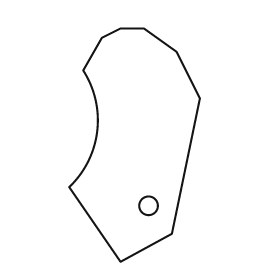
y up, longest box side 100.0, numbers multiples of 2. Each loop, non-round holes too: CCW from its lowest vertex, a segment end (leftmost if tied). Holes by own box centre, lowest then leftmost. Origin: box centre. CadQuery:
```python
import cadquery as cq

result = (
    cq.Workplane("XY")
    .moveTo(-6.0, -50.0)
    .lineTo(16.0, -38.0)
    .lineTo(28.0, 20.0)
    .lineTo(18.0, 40.0)
    .lineTo(4.0, 50.0)
    .lineTo(-6.0, 50.0)
    .lineTo(-14.0, 46.0)
    .lineTo(-22.0, 32.0)
    .threePointArc((-16.0, 6.0), (-28.0, -18.0))
    .close()
    .moveTo(6.0, -26.0)
    .circle(4.0)
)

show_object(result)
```